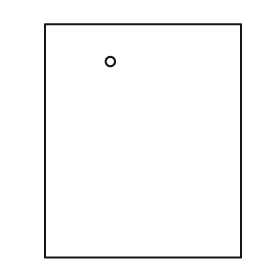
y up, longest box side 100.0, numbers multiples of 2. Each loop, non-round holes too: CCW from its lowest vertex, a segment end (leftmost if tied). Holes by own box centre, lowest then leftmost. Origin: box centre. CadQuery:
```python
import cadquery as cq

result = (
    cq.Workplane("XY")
    .moveTo(-42.0, -50.0)
    .lineTo(42.0, -50.0)
    .lineTo(42.0, 50.0)
    .lineTo(-42.0, 50.0)
    .close()
    .moveTo(-14.0, 34.0)
    .circle(2.0)
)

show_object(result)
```